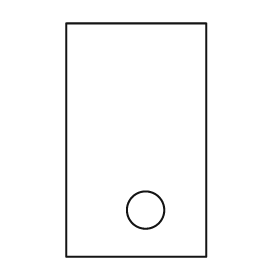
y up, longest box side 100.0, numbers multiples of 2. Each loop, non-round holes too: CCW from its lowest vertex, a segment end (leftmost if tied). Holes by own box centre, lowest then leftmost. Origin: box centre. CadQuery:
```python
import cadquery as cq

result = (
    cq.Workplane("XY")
    .moveTo(-30.0, -50.0)
    .lineTo(30.0, -50.0)
    .lineTo(30.0, 50.0)
    .lineTo(-30.0, 50.0)
    .close()
    .moveTo(4.0, -30.0)
    .circle(8.0)
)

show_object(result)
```